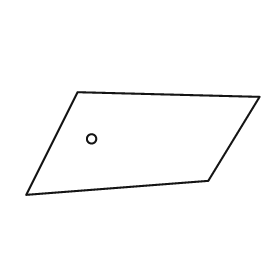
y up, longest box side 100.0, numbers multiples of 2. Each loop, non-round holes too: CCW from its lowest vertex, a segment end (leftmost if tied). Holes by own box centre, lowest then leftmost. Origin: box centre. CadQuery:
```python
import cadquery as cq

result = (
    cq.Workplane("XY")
    .moveTo(-50.0, -22.0)
    .lineTo(28.0, -16.0)
    .lineTo(50.0, 20.0)
    .lineTo(-28.0, 22.0)
    .close()
    .moveTo(-22.0, 2.0)
    .circle(2.0)
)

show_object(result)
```